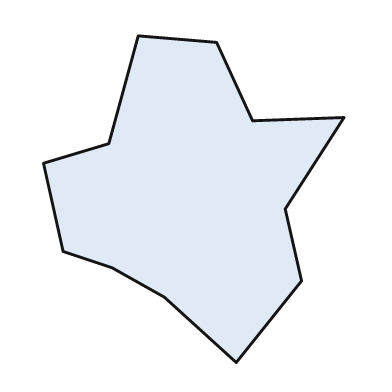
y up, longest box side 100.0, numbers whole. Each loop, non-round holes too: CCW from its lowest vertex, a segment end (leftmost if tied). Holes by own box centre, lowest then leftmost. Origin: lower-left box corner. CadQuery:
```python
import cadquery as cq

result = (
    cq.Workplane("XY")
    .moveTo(59.0, 0.0)
    .lineTo(79.0, 25.0)
    .lineTo(74.0, 47.0)
    .lineTo(92.0, 75.0)
    .lineTo(64.0, 74.0)
    .lineTo(53.0, 98.0)
    .lineTo(29.0, 100.0)
    .lineTo(20.0, 67.0)
    .lineTo(0.0, 61.0)
    .lineTo(6.0, 34.0)
    .lineTo(21.0, 29.0)
    .lineTo(37.0, 20.0)
    .close()
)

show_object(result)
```